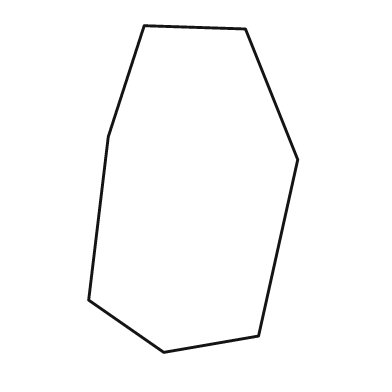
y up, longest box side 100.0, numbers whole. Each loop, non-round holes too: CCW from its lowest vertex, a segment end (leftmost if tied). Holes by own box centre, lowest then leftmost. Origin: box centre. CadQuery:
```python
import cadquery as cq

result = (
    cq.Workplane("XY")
    .moveTo(-9.0, -50.0)
    .lineTo(20.0, -45.0)
    .lineTo(32.0, 9.0)
    .lineTo(16.0, 49.0)
    .lineTo(-15.0, 50.0)
    .lineTo(-26.0, 16.0)
    .lineTo(-32.0, -34.0)
    .close()
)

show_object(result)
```